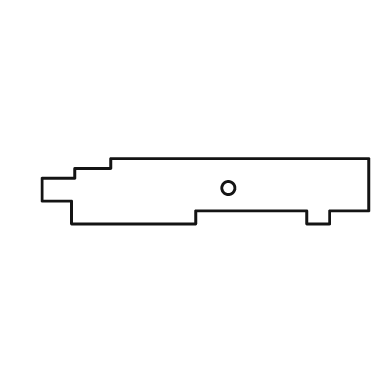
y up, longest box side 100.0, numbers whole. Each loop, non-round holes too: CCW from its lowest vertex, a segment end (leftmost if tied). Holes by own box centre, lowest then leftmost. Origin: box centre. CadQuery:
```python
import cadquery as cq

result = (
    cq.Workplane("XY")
    .moveTo(-41.0, -10.0)
    .lineTo(-3.0, -10.0)
    .lineTo(-3.0, -6.0)
    .lineTo(31.0, -6.0)
    .lineTo(31.0, -10.0)
    .lineTo(38.0, -10.0)
    .lineTo(38.0, -6.0)
    .lineTo(50.0, -6.0)
    .lineTo(50.0, 10.0)
    .lineTo(-29.0, 10.0)
    .lineTo(-29.0, 7.0)
    .lineTo(-40.0, 7.0)
    .lineTo(-40.0, 4.0)
    .lineTo(-50.0, 4.0)
    .lineTo(-50.0, -3.0)
    .lineTo(-41.0, -3.0)
    .close()
    .moveTo(7.0, 1.0)
    .circle(2.0)
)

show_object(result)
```